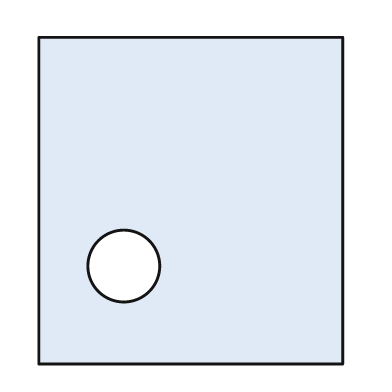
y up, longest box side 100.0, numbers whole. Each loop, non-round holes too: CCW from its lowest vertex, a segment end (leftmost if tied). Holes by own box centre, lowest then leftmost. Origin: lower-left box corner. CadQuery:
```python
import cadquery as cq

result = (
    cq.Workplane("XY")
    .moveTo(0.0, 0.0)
    .lineTo(93.0, 0.0)
    .lineTo(93.0, 100.0)
    .lineTo(0.0, 100.0)
    .close()
    .moveTo(26.0, 30.0)
    .circle(11.0)
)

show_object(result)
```